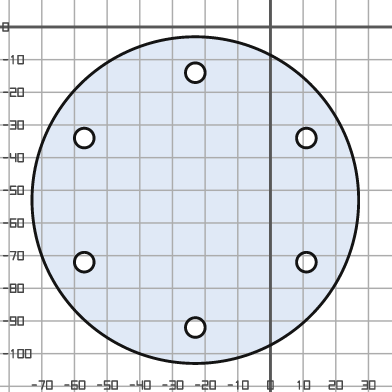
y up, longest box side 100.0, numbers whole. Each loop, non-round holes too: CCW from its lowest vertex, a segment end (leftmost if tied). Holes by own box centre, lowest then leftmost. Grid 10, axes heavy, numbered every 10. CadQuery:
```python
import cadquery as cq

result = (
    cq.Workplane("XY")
    .moveTo(-23.0, -53.0)
    .circle(50.0)
    .moveTo(-23.0, -92.0)
    .circle(3.0)
    .moveTo(-57.0, -72.0)
    .circle(3.0)
    .moveTo(11.0, -72.0)
    .circle(3.0)
    .moveTo(-57.0, -34.0)
    .circle(3.0)
    .moveTo(11.0, -34.0)
    .circle(3.0)
    .moveTo(-23.0, -14.0)
    .circle(3.0)
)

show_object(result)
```